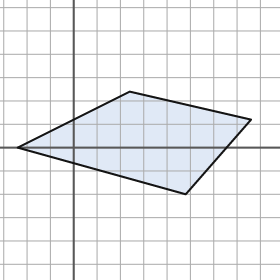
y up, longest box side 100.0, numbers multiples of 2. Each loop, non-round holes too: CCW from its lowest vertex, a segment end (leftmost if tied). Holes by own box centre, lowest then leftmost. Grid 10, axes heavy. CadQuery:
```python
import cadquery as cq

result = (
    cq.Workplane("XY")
    .moveTo(48.0, -20.0)
    .lineTo(76.0, 12.0)
    .lineTo(24.0, 24.0)
    .lineTo(-24.0, 0.0)
    .close()
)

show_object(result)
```